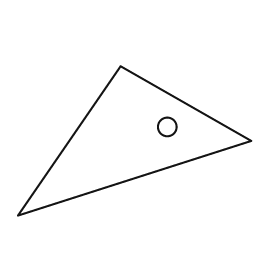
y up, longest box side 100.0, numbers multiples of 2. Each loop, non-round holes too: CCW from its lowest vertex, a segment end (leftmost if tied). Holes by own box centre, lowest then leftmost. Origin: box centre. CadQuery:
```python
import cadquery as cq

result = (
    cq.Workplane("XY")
    .moveTo(-50.0, -32.0)
    .lineTo(50.0, 0.0)
    .lineTo(-6.0, 32.0)
    .close()
    .moveTo(14.0, 6.0)
    .circle(4.0)
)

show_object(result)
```